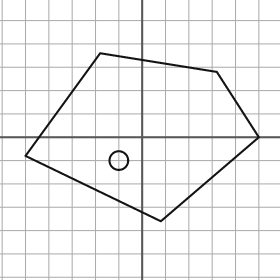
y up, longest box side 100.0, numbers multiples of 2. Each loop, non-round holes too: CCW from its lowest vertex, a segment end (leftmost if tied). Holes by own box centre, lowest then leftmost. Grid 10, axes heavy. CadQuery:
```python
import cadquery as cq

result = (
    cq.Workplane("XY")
    .moveTo(8.0, -36.0)
    .lineTo(50.0, 0.0)
    .lineTo(32.0, 28.0)
    .lineTo(-18.0, 36.0)
    .lineTo(-50.0, -8.0)
    .close()
    .moveTo(-10.0, -10.0)
    .circle(4.0)
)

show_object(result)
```